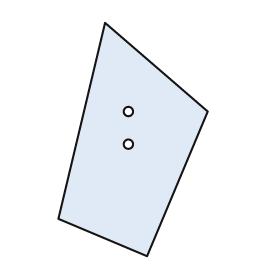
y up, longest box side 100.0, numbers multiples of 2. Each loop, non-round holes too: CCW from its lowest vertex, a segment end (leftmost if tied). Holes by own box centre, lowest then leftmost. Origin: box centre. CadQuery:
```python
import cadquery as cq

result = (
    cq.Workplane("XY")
    .moveTo(6.0, -50.0)
    .lineTo(32.0, 12.0)
    .lineTo(-12.0, 50.0)
    .lineTo(-32.0, -34.0)
    .close()
    .moveTo(-2.0, -2.0)
    .circle(2.0)
    .moveTo(-2.0, 12.0)
    .circle(2.0)
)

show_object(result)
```